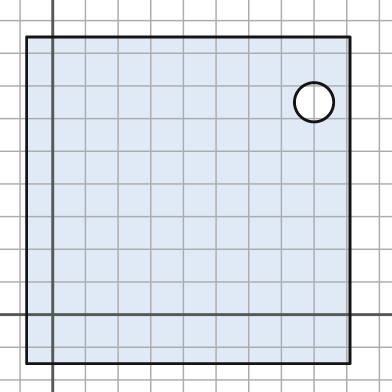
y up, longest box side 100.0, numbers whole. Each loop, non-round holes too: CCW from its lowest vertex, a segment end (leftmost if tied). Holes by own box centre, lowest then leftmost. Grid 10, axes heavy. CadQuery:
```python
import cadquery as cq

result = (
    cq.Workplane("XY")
    .moveTo(-8.0, -15.0)
    .lineTo(91.0, -15.0)
    .lineTo(91.0, 85.0)
    .lineTo(-8.0, 85.0)
    .close()
    .moveTo(80.0, 65.0)
    .circle(6.0)
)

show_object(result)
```